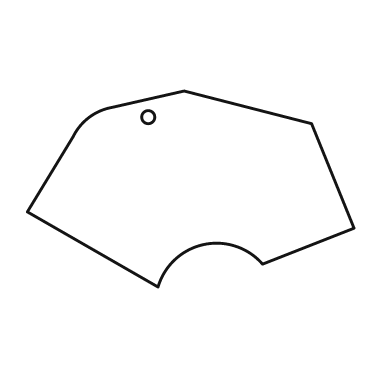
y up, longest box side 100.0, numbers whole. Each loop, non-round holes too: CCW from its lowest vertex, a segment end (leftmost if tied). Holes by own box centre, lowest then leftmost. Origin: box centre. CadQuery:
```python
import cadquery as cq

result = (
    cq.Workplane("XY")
    .moveTo(-10.0, -30.0)
    .threePointArc((4.0, -17.0), (22.0, -23.0))
    .lineTo(50.0, -12.0)
    .lineTo(37.0, 20.0)
    .lineTo(-2.0, 30.0)
    .lineTo(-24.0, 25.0)
    .threePointArc((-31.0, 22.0), (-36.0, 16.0))
    .lineTo(-50.0, -7.0)
    .close()
    .moveTo(-13.0, 22.0)
    .circle(2.0)
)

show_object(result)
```